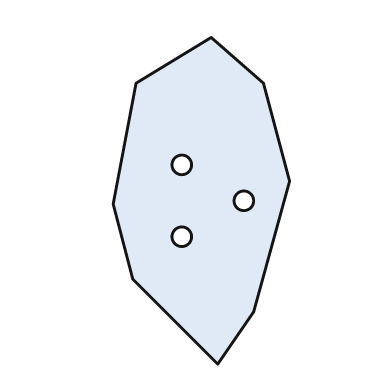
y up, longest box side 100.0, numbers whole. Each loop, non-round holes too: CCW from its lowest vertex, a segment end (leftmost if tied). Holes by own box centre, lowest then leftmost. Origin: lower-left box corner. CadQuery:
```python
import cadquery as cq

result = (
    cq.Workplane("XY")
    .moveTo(32.0, 0.0)
    .lineTo(43.0, 16.0)
    .lineTo(54.0, 56.0)
    .lineTo(46.0, 86.0)
    .lineTo(30.0, 100.0)
    .lineTo(7.0, 86.0)
    .lineTo(0.0, 49.0)
    .lineTo(6.0, 26.0)
    .close()
    .moveTo(21.0, 39.0)
    .circle(3.0)
    .moveTo(40.0, 50.0)
    .circle(3.0)
    .moveTo(21.0, 61.0)
    .circle(3.0)
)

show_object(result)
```